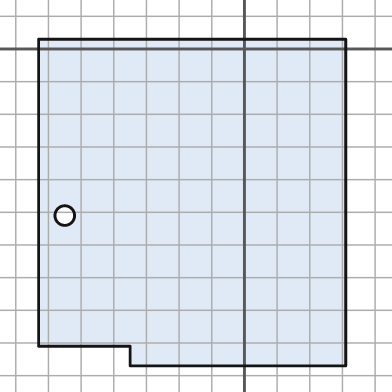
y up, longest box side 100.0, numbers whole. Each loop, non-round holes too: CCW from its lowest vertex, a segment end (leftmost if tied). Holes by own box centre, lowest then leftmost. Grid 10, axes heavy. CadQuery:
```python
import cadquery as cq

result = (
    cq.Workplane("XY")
    .moveTo(-35.0, -97.0)
    .lineTo(31.0, -97.0)
    .lineTo(31.0, 3.0)
    .lineTo(-63.0, 3.0)
    .lineTo(-63.0, -91.0)
    .lineTo(-35.0, -91.0)
    .close()
    .moveTo(-55.0, -51.0)
    .circle(3.0)
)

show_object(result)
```